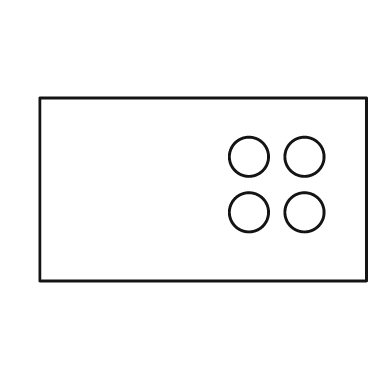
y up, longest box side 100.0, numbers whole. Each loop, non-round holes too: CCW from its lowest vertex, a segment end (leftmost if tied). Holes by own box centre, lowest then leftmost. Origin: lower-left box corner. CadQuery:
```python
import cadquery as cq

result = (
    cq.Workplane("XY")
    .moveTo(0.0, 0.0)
    .lineTo(100.0, 0.0)
    .lineTo(100.0, 56.0)
    .lineTo(0.0, 56.0)
    .close()
    .moveTo(64.0, 21.0)
    .circle(6.0)
    .moveTo(81.0, 21.0)
    .circle(6.0)
    .moveTo(64.0, 38.0)
    .circle(6.0)
    .moveTo(81.0, 38.0)
    .circle(6.0)
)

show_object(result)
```